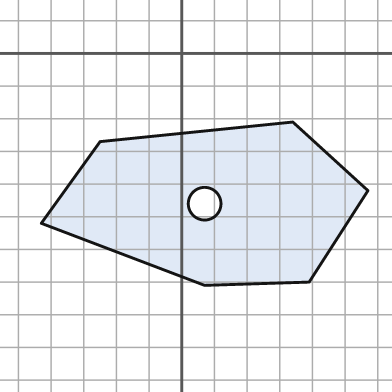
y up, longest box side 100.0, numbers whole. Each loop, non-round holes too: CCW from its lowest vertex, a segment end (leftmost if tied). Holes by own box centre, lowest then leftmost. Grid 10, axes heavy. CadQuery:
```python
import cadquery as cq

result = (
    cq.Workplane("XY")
    .moveTo(7.0, -71.0)
    .lineTo(39.0, -70.0)
    .lineTo(57.0, -42.0)
    .lineTo(34.0, -21.0)
    .lineTo(-25.0, -27.0)
    .lineTo(-43.0, -52.0)
    .close()
    .moveTo(7.0, -46.0)
    .circle(5.0)
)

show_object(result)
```